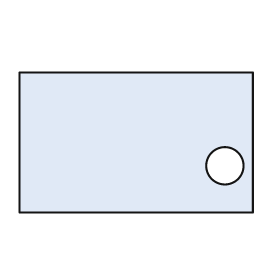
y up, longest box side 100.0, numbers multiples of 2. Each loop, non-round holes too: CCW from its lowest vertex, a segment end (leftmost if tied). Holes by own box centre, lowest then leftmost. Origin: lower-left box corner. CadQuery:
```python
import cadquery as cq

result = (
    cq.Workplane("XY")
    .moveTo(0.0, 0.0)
    .lineTo(100.0, 0.0)
    .lineTo(100.0, 60.0)
    .lineTo(0.0, 60.0)
    .close()
    .moveTo(88.0, 20.0)
    .circle(8.0)
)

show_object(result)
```